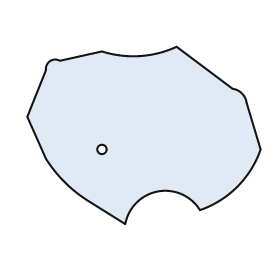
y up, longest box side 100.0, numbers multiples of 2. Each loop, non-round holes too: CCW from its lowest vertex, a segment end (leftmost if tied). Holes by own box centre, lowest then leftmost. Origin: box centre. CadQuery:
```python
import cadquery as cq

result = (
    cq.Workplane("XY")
    .moveTo(-8.0, -38.0)
    .threePointArc((6.0, -24.0), (24.0, -32.0))
    .threePointArc((40.0, -22.0), (50.0, -6.0))
    .lineTo(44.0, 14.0)
    .threePointArc((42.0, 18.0), (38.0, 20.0))
    .lineTo(14.0, 38.0)
    .threePointArc((-2.0, 34.0), (-18.0, 36.0))
    .lineTo(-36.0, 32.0)
    .threePointArc((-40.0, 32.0), (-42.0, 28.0))
    .lineTo(-50.0, 8.0)
    .lineTo(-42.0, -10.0)
    .threePointArc((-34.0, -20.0), (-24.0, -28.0))
    .close()
    .moveTo(-18.0, -6.0)
    .circle(2.0)
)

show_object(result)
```